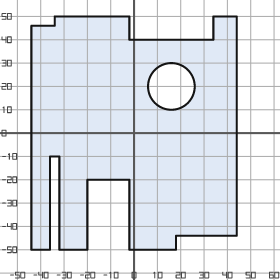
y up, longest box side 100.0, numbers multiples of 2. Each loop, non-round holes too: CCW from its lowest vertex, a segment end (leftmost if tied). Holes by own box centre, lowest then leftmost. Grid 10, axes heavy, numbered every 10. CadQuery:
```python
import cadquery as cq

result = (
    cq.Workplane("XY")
    .moveTo(-44.0, -50.0)
    .lineTo(-36.0, -50.0)
    .lineTo(-36.0, -10.0)
    .lineTo(-32.0, -10.0)
    .lineTo(-32.0, -50.0)
    .lineTo(-20.0, -50.0)
    .lineTo(-20.0, -20.0)
    .lineTo(-2.0, -20.0)
    .lineTo(-2.0, -50.0)
    .lineTo(18.0, -50.0)
    .lineTo(18.0, -44.0)
    .lineTo(44.0, -44.0)
    .lineTo(44.0, 50.0)
    .lineTo(34.0, 50.0)
    .lineTo(34.0, 40.0)
    .lineTo(-2.0, 40.0)
    .lineTo(-2.0, 50.0)
    .lineTo(-34.0, 50.0)
    .lineTo(-34.0, 46.0)
    .lineTo(-44.0, 46.0)
    .close()
    .moveTo(16.0, 20.0)
    .circle(10.0)
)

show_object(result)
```